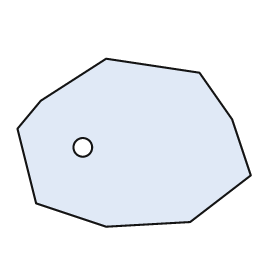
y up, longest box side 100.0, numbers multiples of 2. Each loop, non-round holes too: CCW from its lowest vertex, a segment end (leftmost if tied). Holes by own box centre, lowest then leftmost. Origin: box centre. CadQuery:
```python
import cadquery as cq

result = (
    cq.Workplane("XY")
    .moveTo(-12.0, -36.0)
    .lineTo(24.0, -34.0)
    .lineTo(50.0, -14.0)
    .lineTo(42.0, 10.0)
    .lineTo(28.0, 30.0)
    .lineTo(-12.0, 36.0)
    .lineTo(-40.0, 18.0)
    .lineTo(-50.0, 6.0)
    .lineTo(-42.0, -26.0)
    .close()
    .moveTo(-22.0, -2.0)
    .circle(4.0)
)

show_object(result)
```